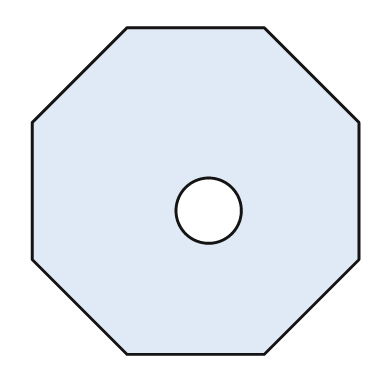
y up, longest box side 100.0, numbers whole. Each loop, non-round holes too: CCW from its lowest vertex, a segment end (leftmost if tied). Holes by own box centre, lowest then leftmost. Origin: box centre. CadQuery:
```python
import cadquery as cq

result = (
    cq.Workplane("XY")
    .moveTo(-21.0, -50.0)
    .lineTo(21.0, -50.0)
    .lineTo(50.0, -21.0)
    .lineTo(50.0, 21.0)
    .lineTo(21.0, 50.0)
    .lineTo(-21.0, 50.0)
    .lineTo(-50.0, 21.0)
    .lineTo(-50.0, -21.0)
    .close()
    .moveTo(4.0, -6.0)
    .circle(10.0)
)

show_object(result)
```